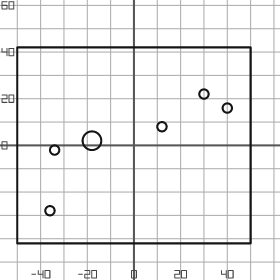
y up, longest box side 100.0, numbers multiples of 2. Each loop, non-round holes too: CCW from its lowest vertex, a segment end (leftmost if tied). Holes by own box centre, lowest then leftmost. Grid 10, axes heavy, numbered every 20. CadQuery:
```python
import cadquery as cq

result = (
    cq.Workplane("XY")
    .moveTo(-50.0, -42.0)
    .lineTo(50.0, -42.0)
    .lineTo(50.0, 42.0)
    .lineTo(-50.0, 42.0)
    .close()
    .moveTo(-36.0, -28.0)
    .circle(2.0)
    .moveTo(-34.0, -2.0)
    .circle(2.0)
    .moveTo(-18.0, 2.0)
    .circle(4.0)
    .moveTo(12.0, 8.0)
    .circle(2.0)
    .moveTo(40.0, 16.0)
    .circle(2.0)
    .moveTo(30.0, 22.0)
    .circle(2.0)
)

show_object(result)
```